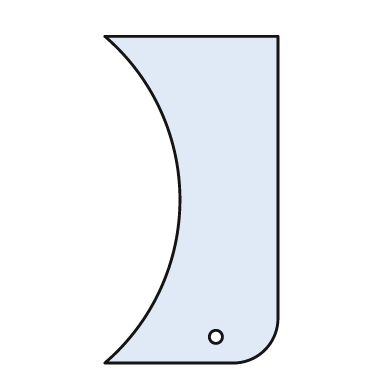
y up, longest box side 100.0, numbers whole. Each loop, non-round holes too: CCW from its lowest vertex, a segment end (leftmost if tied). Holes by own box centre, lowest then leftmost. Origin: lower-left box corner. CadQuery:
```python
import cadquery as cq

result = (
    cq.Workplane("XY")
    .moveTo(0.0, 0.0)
    .lineTo(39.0, 0.0)
    .threePointArc((49.0, 4.0), (53.0, 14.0))
    .lineTo(53.0, 100.0)
    .lineTo(0.0, 100.0)
    .threePointArc((23.0, 50.0), (0.0, 0.0))
    .close()
    .moveTo(34.0, 8.0)
    .circle(2.0)
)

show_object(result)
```